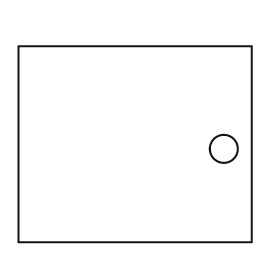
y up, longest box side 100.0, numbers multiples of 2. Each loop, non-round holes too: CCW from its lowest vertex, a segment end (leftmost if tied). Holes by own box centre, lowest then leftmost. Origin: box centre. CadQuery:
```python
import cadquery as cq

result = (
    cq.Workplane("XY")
    .moveTo(-50.0, -42.0)
    .lineTo(50.0, -42.0)
    .lineTo(50.0, 42.0)
    .lineTo(-50.0, 42.0)
    .close()
    .moveTo(38.0, -2.0)
    .circle(6.0)
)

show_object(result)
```